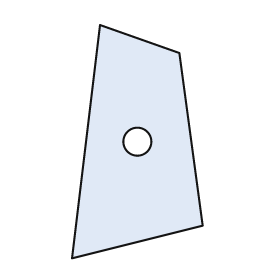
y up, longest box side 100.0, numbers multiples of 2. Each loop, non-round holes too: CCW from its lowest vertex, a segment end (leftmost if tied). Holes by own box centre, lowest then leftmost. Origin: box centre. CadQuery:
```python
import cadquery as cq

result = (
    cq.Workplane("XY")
    .moveTo(-28.0, -50.0)
    .lineTo(28.0, -36.0)
    .lineTo(18.0, 38.0)
    .lineTo(-16.0, 50.0)
    .close()
    .moveTo(0.0, 0.0)
    .circle(6.0)
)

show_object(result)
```